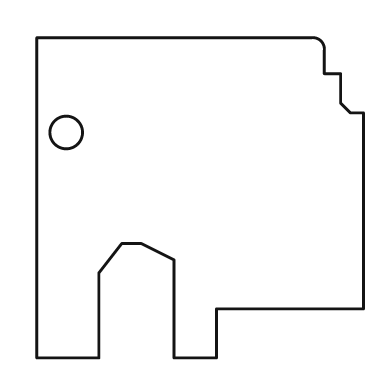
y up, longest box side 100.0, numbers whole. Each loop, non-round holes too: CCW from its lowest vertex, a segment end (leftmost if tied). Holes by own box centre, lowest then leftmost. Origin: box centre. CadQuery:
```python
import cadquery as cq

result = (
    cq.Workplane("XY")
    .moveTo(-50.0, -49.0)
    .lineTo(-31.0, -49.0)
    .lineTo(-31.0, -23.0)
    .lineTo(-24.0, -14.0)
    .lineTo(-18.0, -14.0)
    .lineTo(-8.0, -19.0)
    .lineTo(-8.0, -49.0)
    .lineTo(5.0, -49.0)
    .lineTo(5.0, -34.0)
    .lineTo(50.0, -34.0)
    .lineTo(50.0, 26.0)
    .lineTo(46.0, 26.0)
    .lineTo(43.0, 29.0)
    .lineTo(43.0, 38.0)
    .lineTo(38.0, 38.0)
    .lineTo(38.0, 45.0)
    .threePointArc((37.0, 48.0), (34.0, 49.0))
    .lineTo(-50.0, 49.0)
    .close()
    .moveTo(-41.0, 20.0)
    .circle(5.0)
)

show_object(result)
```